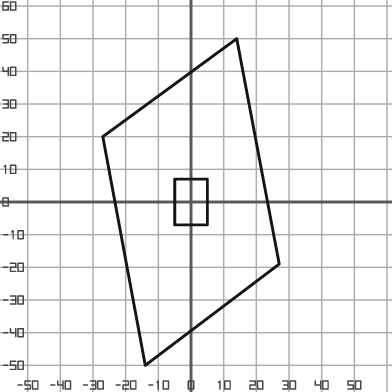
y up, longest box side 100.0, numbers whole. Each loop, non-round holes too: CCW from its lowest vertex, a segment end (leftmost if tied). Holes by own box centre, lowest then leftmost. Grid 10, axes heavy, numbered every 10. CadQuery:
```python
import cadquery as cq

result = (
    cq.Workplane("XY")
    .moveTo(-14.0, -50.0)
    .lineTo(27.0, -19.0)
    .lineTo(14.0, 50.0)
    .lineTo(-27.0, 20.0)
    .close()
    .moveTo(-5.0, -7.0)
    .lineTo(5.0, -7.0)
    .lineTo(5.0, 7.0)
    .lineTo(-5.0, 7.0)
    .close()
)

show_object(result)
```